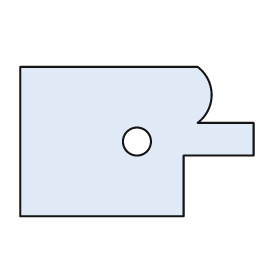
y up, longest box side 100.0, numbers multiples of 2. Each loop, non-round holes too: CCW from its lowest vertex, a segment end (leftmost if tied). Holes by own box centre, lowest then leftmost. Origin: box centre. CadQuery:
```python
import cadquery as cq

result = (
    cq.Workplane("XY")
    .moveTo(-50.0, -32.0)
    .lineTo(20.0, -32.0)
    .lineTo(20.0, -6.0)
    .lineTo(50.0, -6.0)
    .lineTo(50.0, 8.0)
    .lineTo(26.0, 8.0)
    .threePointArc((32.0, 20.0), (26.0, 32.0))
    .lineTo(-50.0, 32.0)
    .close()
    .moveTo(0.0, 0.0)
    .circle(6.0)
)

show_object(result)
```